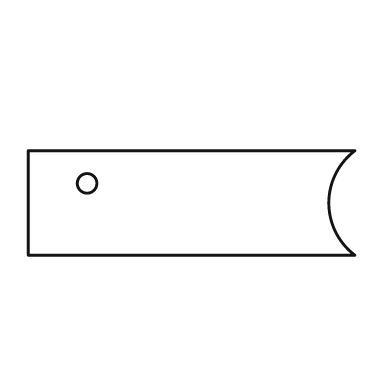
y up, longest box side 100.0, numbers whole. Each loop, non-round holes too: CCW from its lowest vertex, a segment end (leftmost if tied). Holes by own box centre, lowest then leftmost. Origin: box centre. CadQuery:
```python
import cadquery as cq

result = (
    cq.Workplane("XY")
    .moveTo(-50.0, -16.0)
    .lineTo(50.0, -16.0)
    .threePointArc((42.0, 0.0), (50.0, 16.0))
    .lineTo(-50.0, 16.0)
    .close()
    .moveTo(-32.0, 6.0)
    .circle(3.0)
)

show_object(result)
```